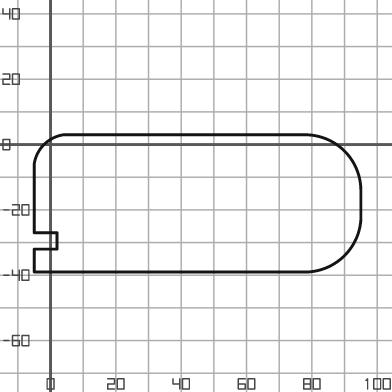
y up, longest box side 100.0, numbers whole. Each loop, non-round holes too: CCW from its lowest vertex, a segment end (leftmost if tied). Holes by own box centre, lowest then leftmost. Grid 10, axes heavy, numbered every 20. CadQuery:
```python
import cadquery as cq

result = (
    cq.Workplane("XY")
    .moveTo(-5.0, -39.0)
    .lineTo(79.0, -39.0)
    .threePointArc((90.0, -34.0), (95.0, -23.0))
    .lineTo(95.0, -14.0)
    .threePointArc((90.0, -2.0), (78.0, 3.0))
    .lineTo(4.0, 3.0)
    .threePointArc((-2.0, 0.0), (-5.0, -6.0))
    .lineTo(-5.0, -27.0)
    .lineTo(2.0, -27.0)
    .lineTo(2.0, -32.0)
    .lineTo(-5.0, -32.0)
    .close()
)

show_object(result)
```